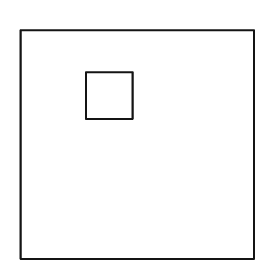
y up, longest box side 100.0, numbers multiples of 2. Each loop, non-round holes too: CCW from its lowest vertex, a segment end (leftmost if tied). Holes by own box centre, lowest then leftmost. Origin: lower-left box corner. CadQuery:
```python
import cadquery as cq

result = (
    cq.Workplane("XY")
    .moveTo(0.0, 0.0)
    .lineTo(100.0, 0.0)
    .lineTo(100.0, 98.0)
    .lineTo(0.0, 98.0)
    .close()
    .moveTo(28.0, 60.0)
    .lineTo(48.0, 60.0)
    .lineTo(48.0, 80.0)
    .lineTo(28.0, 80.0)
    .close()
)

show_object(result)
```